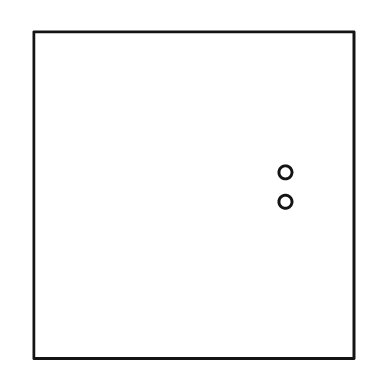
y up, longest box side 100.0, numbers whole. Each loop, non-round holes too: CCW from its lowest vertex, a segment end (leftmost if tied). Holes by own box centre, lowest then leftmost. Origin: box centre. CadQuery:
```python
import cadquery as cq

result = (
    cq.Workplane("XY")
    .moveTo(-49.0, -50.0)
    .lineTo(49.0, -50.0)
    .lineTo(49.0, 50.0)
    .lineTo(-49.0, 50.0)
    .close()
    .moveTo(28.0, -2.0)
    .circle(2.0)
    .moveTo(28.0, 7.0)
    .circle(2.0)
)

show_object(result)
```